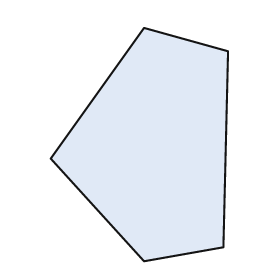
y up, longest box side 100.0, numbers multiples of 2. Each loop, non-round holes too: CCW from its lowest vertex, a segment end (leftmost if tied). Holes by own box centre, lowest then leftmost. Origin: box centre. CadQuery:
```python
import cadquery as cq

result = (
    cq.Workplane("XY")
    .moveTo(2.0, -50.0)
    .lineTo(36.0, -44.0)
    .lineTo(38.0, 40.0)
    .lineTo(2.0, 50.0)
    .lineTo(-38.0, -6.0)
    .close()
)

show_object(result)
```